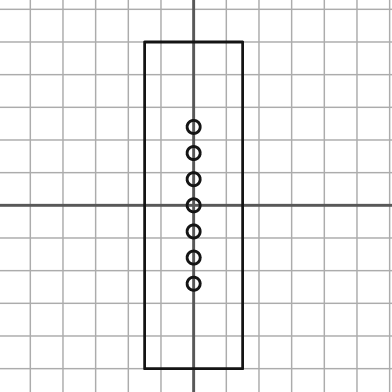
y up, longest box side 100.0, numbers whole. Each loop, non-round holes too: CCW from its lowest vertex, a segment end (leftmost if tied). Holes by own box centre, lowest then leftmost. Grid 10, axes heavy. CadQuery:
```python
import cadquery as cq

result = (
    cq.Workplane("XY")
    .moveTo(-15.0, -50.0)
    .lineTo(15.0, -50.0)
    .lineTo(15.0, 50.0)
    .lineTo(-15.0, 50.0)
    .close()
    .moveTo(0.0, -24.0)
    .circle(2.0)
    .moveTo(0.0, -16.0)
    .circle(2.0)
    .moveTo(0.0, -8.0)
    .circle(2.0)
    .moveTo(0.0, 0.0)
    .circle(2.0)
    .moveTo(0.0, 8.0)
    .circle(2.0)
    .moveTo(0.0, 16.0)
    .circle(2.0)
    .moveTo(0.0, 24.0)
    .circle(2.0)
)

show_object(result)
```